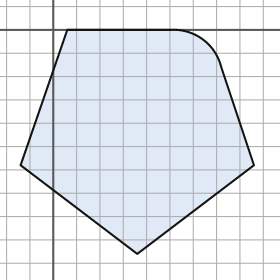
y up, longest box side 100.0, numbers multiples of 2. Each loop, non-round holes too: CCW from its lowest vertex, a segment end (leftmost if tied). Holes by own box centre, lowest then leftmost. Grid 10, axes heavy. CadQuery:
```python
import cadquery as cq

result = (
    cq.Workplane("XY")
    .moveTo(36.0, -96.0)
    .lineTo(86.0, -58.0)
    .lineTo(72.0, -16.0)
    .threePointArc((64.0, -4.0), (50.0, 0.0))
    .lineTo(6.0, 0.0)
    .lineTo(-14.0, -58.0)
    .close()
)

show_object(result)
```